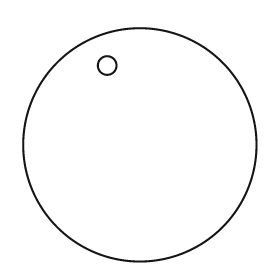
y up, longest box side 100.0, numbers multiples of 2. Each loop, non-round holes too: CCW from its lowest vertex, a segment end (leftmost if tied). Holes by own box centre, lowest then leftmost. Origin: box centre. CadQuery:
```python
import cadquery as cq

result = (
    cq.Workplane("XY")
    .moveTo(0.0, 0.0)
    .circle(50.0)
    .moveTo(-14.0, 34.0)
    .circle(4.0)
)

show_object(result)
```